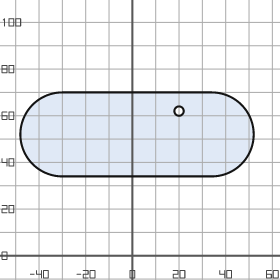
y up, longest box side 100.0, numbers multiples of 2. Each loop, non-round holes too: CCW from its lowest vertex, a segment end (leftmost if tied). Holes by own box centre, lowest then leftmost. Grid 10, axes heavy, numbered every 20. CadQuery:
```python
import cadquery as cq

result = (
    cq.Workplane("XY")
    .moveTo(-30.0, 34.0)
    .lineTo(34.0, 34.0)
    .threePointArc((52.0, 52.0), (34.0, 70.0))
    .lineTo(-30.0, 70.0)
    .threePointArc((-48.0, 52.0), (-30.0, 34.0))
    .close()
    .moveTo(20.0, 62.0)
    .circle(2.0)
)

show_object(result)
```